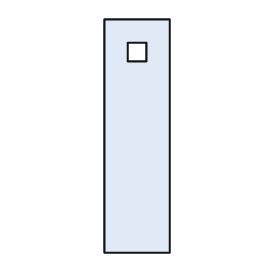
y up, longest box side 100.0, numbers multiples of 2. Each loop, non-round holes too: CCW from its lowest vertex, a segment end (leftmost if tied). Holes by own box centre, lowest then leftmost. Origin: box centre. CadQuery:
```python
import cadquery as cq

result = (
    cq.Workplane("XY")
    .moveTo(-14.0, -50.0)
    .lineTo(14.0, -50.0)
    .lineTo(14.0, 50.0)
    .lineTo(-14.0, 50.0)
    .close()
    .moveTo(-4.0, 32.0)
    .lineTo(4.0, 32.0)
    .lineTo(4.0, 40.0)
    .lineTo(-4.0, 40.0)
    .close()
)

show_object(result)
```